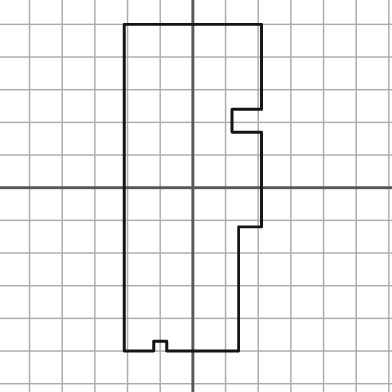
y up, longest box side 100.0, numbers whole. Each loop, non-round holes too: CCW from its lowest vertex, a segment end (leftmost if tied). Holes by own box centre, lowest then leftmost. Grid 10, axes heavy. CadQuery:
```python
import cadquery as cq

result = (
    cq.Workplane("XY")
    .moveTo(-21.0, -50.0)
    .lineTo(-12.0, -50.0)
    .lineTo(-12.0, -47.0)
    .lineTo(-8.0, -47.0)
    .lineTo(-8.0, -50.0)
    .lineTo(14.0, -50.0)
    .lineTo(14.0, -12.0)
    .lineTo(21.0, -12.0)
    .lineTo(21.0, 17.0)
    .lineTo(12.0, 17.0)
    .lineTo(12.0, 24.0)
    .lineTo(21.0, 24.0)
    .lineTo(21.0, 50.0)
    .lineTo(-21.0, 50.0)
    .close()
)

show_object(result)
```